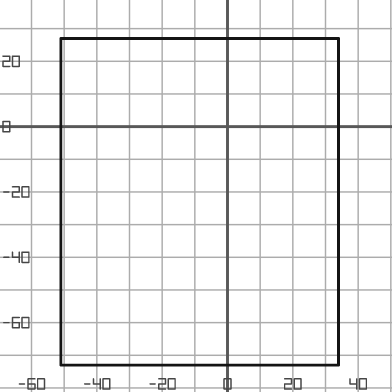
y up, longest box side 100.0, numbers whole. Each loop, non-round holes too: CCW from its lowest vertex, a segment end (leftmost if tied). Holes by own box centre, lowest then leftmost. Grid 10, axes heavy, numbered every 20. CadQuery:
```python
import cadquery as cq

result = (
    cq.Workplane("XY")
    .moveTo(-51.0, -73.0)
    .lineTo(34.0, -73.0)
    .lineTo(34.0, 27.0)
    .lineTo(-51.0, 27.0)
    .close()
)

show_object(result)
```